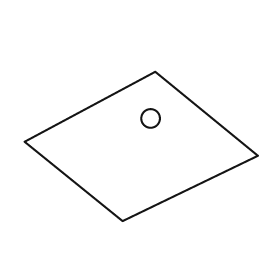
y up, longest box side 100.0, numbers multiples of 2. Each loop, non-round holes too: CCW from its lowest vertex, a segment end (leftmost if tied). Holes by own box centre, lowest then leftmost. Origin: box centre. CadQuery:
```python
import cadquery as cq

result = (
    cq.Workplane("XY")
    .moveTo(-8.0, -32.0)
    .lineTo(50.0, -4.0)
    .lineTo(6.0, 32.0)
    .lineTo(-50.0, 2.0)
    .close()
    .moveTo(4.0, 12.0)
    .circle(4.0)
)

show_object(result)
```